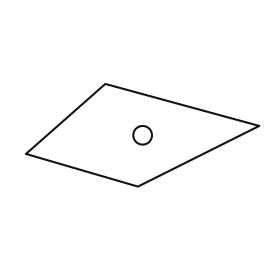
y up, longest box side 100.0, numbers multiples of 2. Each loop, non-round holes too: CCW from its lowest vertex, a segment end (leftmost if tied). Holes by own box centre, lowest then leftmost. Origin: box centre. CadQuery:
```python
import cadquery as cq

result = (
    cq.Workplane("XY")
    .moveTo(-2.0, -22.0)
    .lineTo(50.0, 4.0)
    .lineTo(-16.0, 22.0)
    .lineTo(-50.0, -8.0)
    .close()
    .moveTo(0.0, 0.0)
    .circle(4.0)
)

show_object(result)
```